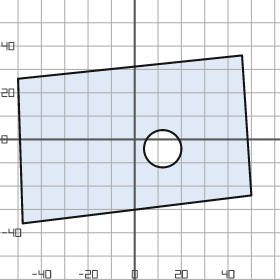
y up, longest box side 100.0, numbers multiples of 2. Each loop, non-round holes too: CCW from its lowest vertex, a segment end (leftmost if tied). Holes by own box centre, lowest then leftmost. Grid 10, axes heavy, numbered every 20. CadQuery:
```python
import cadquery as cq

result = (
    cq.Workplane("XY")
    .moveTo(-48.0, -36.0)
    .lineTo(50.0, -24.0)
    .lineTo(46.0, 36.0)
    .lineTo(-50.0, 26.0)
    .close()
    .moveTo(12.0, -4.0)
    .circle(8.0)
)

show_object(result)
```